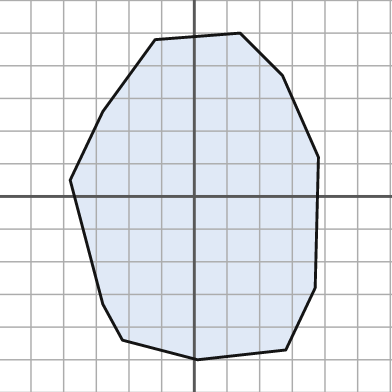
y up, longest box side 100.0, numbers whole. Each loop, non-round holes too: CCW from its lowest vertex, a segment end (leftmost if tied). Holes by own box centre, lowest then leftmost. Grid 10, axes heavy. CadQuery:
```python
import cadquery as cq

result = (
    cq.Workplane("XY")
    .moveTo(1.0, -50.0)
    .lineTo(28.0, -47.0)
    .lineTo(37.0, -28.0)
    .lineTo(38.0, 12.0)
    .lineTo(27.0, 37.0)
    .lineTo(14.0, 50.0)
    .lineTo(-12.0, 48.0)
    .lineTo(-28.0, 26.0)
    .lineTo(-38.0, 5.0)
    .lineTo(-28.0, -33.0)
    .lineTo(-22.0, -44.0)
    .close()
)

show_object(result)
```